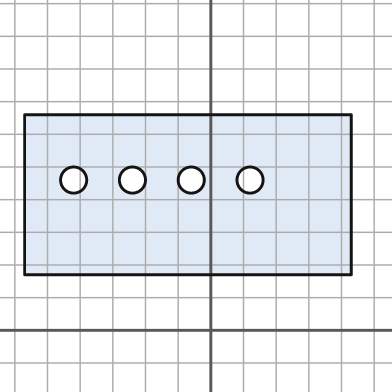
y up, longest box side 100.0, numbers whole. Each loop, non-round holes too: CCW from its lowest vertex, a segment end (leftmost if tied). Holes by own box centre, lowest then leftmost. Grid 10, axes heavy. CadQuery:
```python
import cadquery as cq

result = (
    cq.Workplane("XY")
    .moveTo(-57.0, 17.0)
    .lineTo(43.0, 17.0)
    .lineTo(43.0, 66.0)
    .lineTo(-57.0, 66.0)
    .close()
    .moveTo(-42.0, 46.0)
    .circle(4.0)
    .moveTo(-24.0, 46.0)
    .circle(4.0)
    .moveTo(-6.0, 46.0)
    .circle(4.0)
    .moveTo(12.0, 46.0)
    .circle(4.0)
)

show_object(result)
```